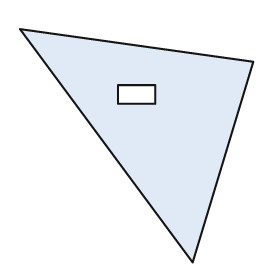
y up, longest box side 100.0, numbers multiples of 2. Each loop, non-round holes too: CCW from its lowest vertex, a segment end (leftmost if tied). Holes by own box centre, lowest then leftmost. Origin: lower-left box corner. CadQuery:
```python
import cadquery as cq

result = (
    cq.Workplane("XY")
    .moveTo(74.0, 0.0)
    .lineTo(100.0, 86.0)
    .lineTo(0.0, 100.0)
    .close()
    .moveTo(42.0, 68.0)
    .lineTo(58.0, 68.0)
    .lineTo(58.0, 76.0)
    .lineTo(42.0, 76.0)
    .close()
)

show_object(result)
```